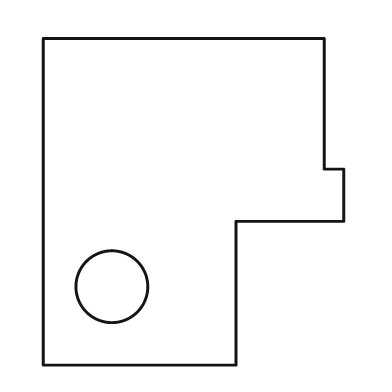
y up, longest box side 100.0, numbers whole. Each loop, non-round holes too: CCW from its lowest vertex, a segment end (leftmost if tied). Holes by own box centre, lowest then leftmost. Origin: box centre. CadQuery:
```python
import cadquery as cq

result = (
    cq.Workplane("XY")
    .moveTo(-46.0, -50.0)
    .lineTo(13.0, -50.0)
    .lineTo(13.0, -6.0)
    .lineTo(46.0, -6.0)
    .lineTo(46.0, 10.0)
    .lineTo(40.0, 10.0)
    .lineTo(40.0, 50.0)
    .lineTo(-46.0, 50.0)
    .close()
    .moveTo(-25.0, -26.0)
    .circle(11.0)
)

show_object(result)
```